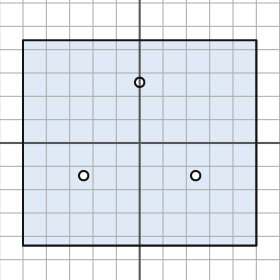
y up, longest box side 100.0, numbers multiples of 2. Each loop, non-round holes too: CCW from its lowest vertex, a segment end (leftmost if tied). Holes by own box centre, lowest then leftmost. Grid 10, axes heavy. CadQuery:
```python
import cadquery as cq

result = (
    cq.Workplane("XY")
    .moveTo(-50.0, -44.0)
    .lineTo(50.0, -44.0)
    .lineTo(50.0, 44.0)
    .lineTo(-50.0, 44.0)
    .close()
    .moveTo(-24.0, -14.0)
    .circle(2.0)
    .moveTo(24.0, -14.0)
    .circle(2.0)
    .moveTo(0.0, 26.0)
    .circle(2.0)
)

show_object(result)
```